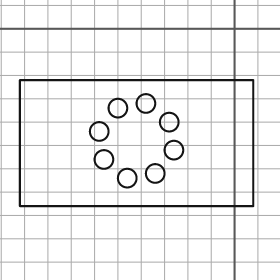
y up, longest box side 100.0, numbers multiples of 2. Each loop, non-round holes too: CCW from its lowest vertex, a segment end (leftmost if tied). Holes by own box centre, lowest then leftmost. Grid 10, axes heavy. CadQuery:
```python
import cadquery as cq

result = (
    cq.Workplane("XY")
    .moveTo(-92.0, -76.0)
    .lineTo(8.0, -76.0)
    .lineTo(8.0, -22.0)
    .lineTo(-92.0, -22.0)
    .close()
    .moveTo(-46.0, -64.0)
    .circle(4.0)
    .moveTo(-34.0, -62.0)
    .circle(4.0)
    .moveTo(-56.0, -56.0)
    .circle(4.0)
    .moveTo(-26.0, -52.0)
    .circle(4.0)
    .moveTo(-58.0, -44.0)
    .circle(4.0)
    .moveTo(-28.0, -40.0)
    .circle(4.0)
    .moveTo(-50.0, -34.0)
    .circle(4.0)
    .moveTo(-38.0, -32.0)
    .circle(4.0)
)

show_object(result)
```